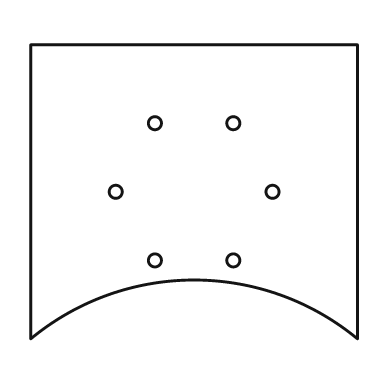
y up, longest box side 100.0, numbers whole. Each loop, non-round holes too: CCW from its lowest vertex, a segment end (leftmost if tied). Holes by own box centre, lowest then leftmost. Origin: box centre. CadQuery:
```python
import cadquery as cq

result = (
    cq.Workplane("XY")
    .moveTo(-50.0, -45.0)
    .threePointArc((0.0, -27.0), (50.0, -45.0))
    .lineTo(50.0, 45.0)
    .lineTo(-50.0, 45.0)
    .close()
    .moveTo(-12.0, -21.0)
    .circle(2.0)
    .moveTo(12.0, -21.0)
    .circle(2.0)
    .moveTo(-24.0, 0.0)
    .circle(2.0)
    .moveTo(24.0, 0.0)
    .circle(2.0)
    .moveTo(-12.0, 21.0)
    .circle(2.0)
    .moveTo(12.0, 21.0)
    .circle(2.0)
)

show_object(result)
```